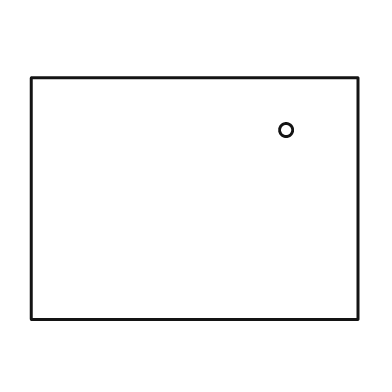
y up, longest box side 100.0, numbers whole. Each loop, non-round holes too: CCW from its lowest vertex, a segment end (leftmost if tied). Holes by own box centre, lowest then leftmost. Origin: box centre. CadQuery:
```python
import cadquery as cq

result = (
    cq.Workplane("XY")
    .moveTo(-50.0, -37.0)
    .lineTo(50.0, -37.0)
    .lineTo(50.0, 37.0)
    .lineTo(-50.0, 37.0)
    .close()
    .moveTo(28.0, 21.0)
    .circle(2.0)
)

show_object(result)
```